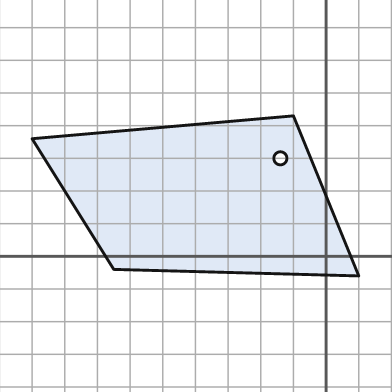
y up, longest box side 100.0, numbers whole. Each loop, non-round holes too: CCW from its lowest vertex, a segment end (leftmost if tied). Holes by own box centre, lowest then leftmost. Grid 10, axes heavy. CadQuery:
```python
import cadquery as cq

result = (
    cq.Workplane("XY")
    .moveTo(10.0, -6.0)
    .lineTo(-10.0, 43.0)
    .lineTo(-90.0, 36.0)
    .lineTo(-65.0, -4.0)
    .close()
    .moveTo(-14.0, 30.0)
    .circle(2.0)
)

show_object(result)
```